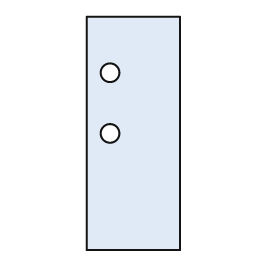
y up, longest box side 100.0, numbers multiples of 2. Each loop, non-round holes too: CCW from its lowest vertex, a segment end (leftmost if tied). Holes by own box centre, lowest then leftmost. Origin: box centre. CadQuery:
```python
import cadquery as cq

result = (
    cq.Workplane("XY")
    .moveTo(-20.0, -50.0)
    .lineTo(20.0, -50.0)
    .lineTo(20.0, 50.0)
    .lineTo(-20.0, 50.0)
    .close()
    .moveTo(-10.0, 0.0)
    .circle(4.0)
    .moveTo(-10.0, 26.0)
    .circle(4.0)
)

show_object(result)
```